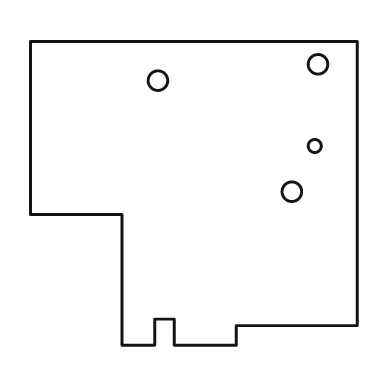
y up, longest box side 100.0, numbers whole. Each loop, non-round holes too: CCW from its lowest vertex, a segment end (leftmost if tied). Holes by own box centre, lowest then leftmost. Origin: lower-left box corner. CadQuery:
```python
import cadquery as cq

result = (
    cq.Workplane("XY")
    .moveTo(28.0, 0.0)
    .lineTo(38.0, 0.0)
    .lineTo(38.0, 8.0)
    .lineTo(44.0, 8.0)
    .lineTo(44.0, 0.0)
    .lineTo(63.0, 0.0)
    .lineTo(63.0, 6.0)
    .lineTo(100.0, 6.0)
    .lineTo(100.0, 93.0)
    .lineTo(0.0, 93.0)
    .lineTo(0.0, 40.0)
    .lineTo(28.0, 40.0)
    .close()
    .moveTo(80.0, 47.0)
    .circle(3.0)
    .moveTo(87.0, 61.0)
    .circle(2.0)
    .moveTo(39.0, 81.0)
    .circle(3.0)
    .moveTo(88.0, 86.0)
    .circle(3.0)
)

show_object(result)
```